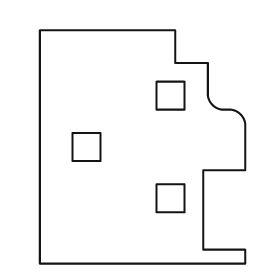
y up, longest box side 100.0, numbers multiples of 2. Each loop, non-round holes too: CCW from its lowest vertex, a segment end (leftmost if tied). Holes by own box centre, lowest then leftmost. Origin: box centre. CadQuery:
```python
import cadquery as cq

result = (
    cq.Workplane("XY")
    .moveTo(-44.0, -50.0)
    .lineTo(44.0, -50.0)
    .lineTo(44.0, -44.0)
    .lineTo(26.0, -44.0)
    .lineTo(26.0, -10.0)
    .lineTo(44.0, -10.0)
    .lineTo(44.0, 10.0)
    .threePointArc((42.0, 14.0), (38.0, 16.0))
    .lineTo(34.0, 16.0)
    .threePointArc((30.0, 18.0), (28.0, 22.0))
    .lineTo(28.0, 36.0)
    .lineTo(14.0, 36.0)
    .lineTo(14.0, 50.0)
    .lineTo(-44.0, 50.0)
    .close()
    .moveTo(6.0, -28.0)
    .lineTo(18.0, -28.0)
    .lineTo(18.0, -16.0)
    .lineTo(6.0, -16.0)
    .close()
    .moveTo(-30.0, -6.0)
    .lineTo(-18.0, -6.0)
    .lineTo(-18.0, 6.0)
    .lineTo(-30.0, 6.0)
    .close()
    .moveTo(6.0, 16.0)
    .lineTo(18.0, 16.0)
    .lineTo(18.0, 28.0)
    .lineTo(6.0, 28.0)
    .close()
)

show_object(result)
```